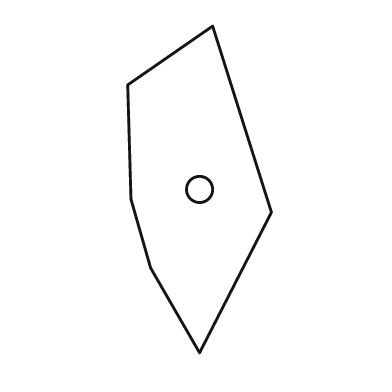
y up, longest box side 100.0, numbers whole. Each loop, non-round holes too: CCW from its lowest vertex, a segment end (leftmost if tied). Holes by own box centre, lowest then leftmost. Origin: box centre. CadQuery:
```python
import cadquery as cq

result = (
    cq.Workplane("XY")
    .moveTo(0.0, -50.0)
    .lineTo(22.0, -7.0)
    .lineTo(4.0, 50.0)
    .lineTo(-22.0, 32.0)
    .lineTo(-21.0, -3.0)
    .lineTo(-15.0, -24.0)
    .close()
    .moveTo(0.0, 0.0)
    .circle(4.0)
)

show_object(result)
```